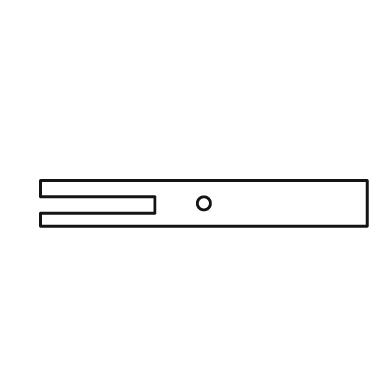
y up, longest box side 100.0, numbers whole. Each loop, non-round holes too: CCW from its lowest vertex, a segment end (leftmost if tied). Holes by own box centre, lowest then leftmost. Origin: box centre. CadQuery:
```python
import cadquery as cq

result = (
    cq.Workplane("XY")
    .moveTo(-50.0, -7.0)
    .lineTo(50.0, -7.0)
    .lineTo(50.0, 7.0)
    .lineTo(-50.0, 7.0)
    .lineTo(-50.0, 2.0)
    .lineTo(-15.0, 2.0)
    .lineTo(-15.0, -3.0)
    .lineTo(-50.0, -3.0)
    .close()
    .moveTo(0.0, 0.0)
    .circle(2.0)
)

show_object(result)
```